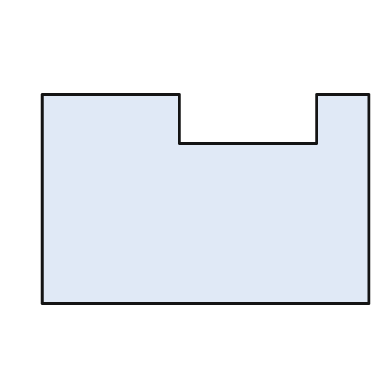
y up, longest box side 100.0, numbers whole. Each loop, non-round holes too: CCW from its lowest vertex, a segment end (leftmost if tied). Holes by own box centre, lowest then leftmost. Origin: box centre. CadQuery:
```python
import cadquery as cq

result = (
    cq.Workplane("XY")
    .moveTo(-50.0, -32.0)
    .lineTo(50.0, -32.0)
    .lineTo(50.0, 32.0)
    .lineTo(34.0, 32.0)
    .lineTo(34.0, 17.0)
    .lineTo(-8.0, 17.0)
    .lineTo(-8.0, 32.0)
    .lineTo(-50.0, 32.0)
    .close()
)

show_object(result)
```